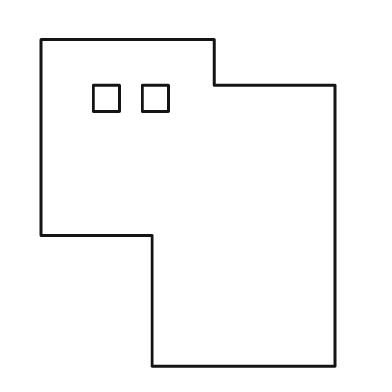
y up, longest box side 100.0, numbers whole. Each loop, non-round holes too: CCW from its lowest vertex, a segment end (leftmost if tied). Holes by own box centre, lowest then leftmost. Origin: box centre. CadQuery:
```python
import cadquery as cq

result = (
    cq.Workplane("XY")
    .moveTo(-11.0, -50.0)
    .lineTo(45.0, -50.0)
    .lineTo(45.0, 36.0)
    .lineTo(8.0, 36.0)
    .lineTo(8.0, 50.0)
    .lineTo(-45.0, 50.0)
    .lineTo(-45.0, -10.0)
    .lineTo(-11.0, -10.0)
    .close()
    .moveTo(-29.0, 28.0)
    .lineTo(-21.0, 28.0)
    .lineTo(-21.0, 36.0)
    .lineTo(-29.0, 36.0)
    .close()
    .moveTo(-14.0, 28.0)
    .lineTo(-6.0, 28.0)
    .lineTo(-6.0, 36.0)
    .lineTo(-14.0, 36.0)
    .close()
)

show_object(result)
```